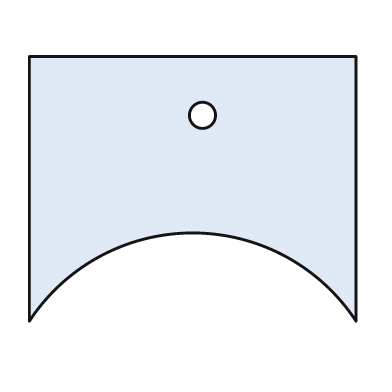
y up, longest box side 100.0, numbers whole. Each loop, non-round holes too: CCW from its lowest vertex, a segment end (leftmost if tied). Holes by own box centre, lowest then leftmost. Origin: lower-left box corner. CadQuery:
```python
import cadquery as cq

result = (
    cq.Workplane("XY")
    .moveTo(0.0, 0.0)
    .threePointArc((50.0, 27.0), (100.0, 0.0))
    .lineTo(100.0, 81.0)
    .lineTo(0.0, 81.0)
    .close()
    .moveTo(53.0, 63.0)
    .circle(4.0)
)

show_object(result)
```